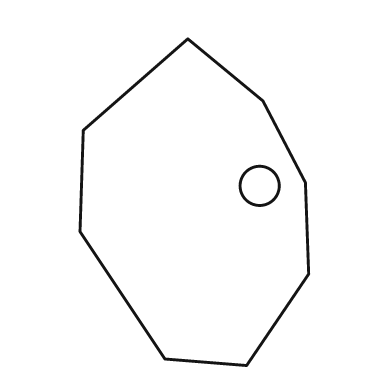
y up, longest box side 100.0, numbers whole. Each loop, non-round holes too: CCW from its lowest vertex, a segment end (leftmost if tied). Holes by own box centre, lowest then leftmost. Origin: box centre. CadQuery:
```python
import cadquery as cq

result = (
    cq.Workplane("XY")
    .moveTo(16.0, -50.0)
    .lineTo(35.0, -22.0)
    .lineTo(34.0, 6.0)
    .lineTo(21.0, 31.0)
    .lineTo(-2.0, 50.0)
    .lineTo(-34.0, 22.0)
    .lineTo(-35.0, -9.0)
    .lineTo(-9.0, -48.0)
    .close()
    .moveTo(20.0, 5.0)
    .circle(6.0)
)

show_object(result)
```